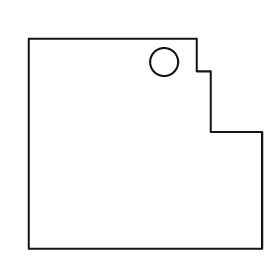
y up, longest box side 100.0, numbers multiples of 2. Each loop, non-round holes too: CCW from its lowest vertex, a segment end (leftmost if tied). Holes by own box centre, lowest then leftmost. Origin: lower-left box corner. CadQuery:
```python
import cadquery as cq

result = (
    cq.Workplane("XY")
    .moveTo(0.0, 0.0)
    .lineTo(100.0, 0.0)
    .lineTo(100.0, 50.0)
    .lineTo(78.0, 50.0)
    .lineTo(78.0, 76.0)
    .lineTo(72.0, 76.0)
    .lineTo(72.0, 90.0)
    .lineTo(0.0, 90.0)
    .close()
    .moveTo(58.0, 80.0)
    .circle(6.0)
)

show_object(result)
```